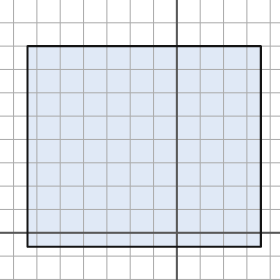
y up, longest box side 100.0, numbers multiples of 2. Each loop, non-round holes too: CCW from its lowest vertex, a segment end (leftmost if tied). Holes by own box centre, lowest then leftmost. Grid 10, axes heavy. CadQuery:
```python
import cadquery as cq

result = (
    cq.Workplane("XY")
    .moveTo(-64.0, -6.0)
    .lineTo(36.0, -6.0)
    .lineTo(36.0, 80.0)
    .lineTo(-64.0, 80.0)
    .close()
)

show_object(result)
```